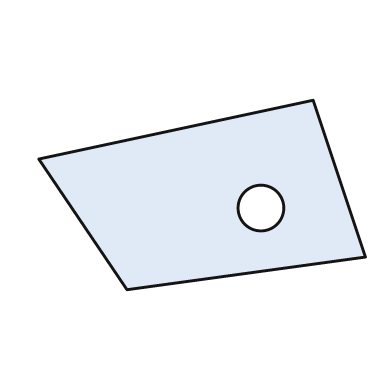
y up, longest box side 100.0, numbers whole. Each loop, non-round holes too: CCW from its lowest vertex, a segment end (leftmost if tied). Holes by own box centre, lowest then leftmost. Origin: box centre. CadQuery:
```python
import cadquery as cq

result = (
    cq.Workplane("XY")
    .moveTo(-23.0, -29.0)
    .lineTo(50.0, -19.0)
    .lineTo(34.0, 29.0)
    .lineTo(-50.0, 11.0)
    .close()
    .moveTo(18.0, -4.0)
    .circle(7.0)
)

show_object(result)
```